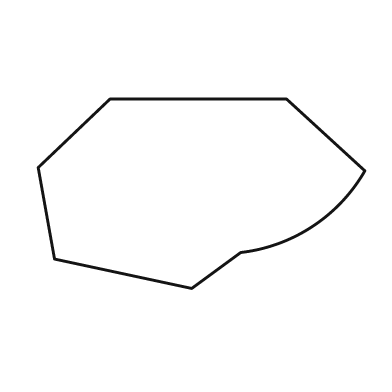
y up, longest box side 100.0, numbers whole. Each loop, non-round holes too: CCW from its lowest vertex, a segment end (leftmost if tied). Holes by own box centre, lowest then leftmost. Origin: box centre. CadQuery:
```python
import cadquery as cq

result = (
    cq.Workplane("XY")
    .moveTo(-3.0, -29.0)
    .lineTo(12.0, -18.0)
    .threePointArc((34.0, -10.0), (50.0, 7.0))
    .lineTo(26.0, 29.0)
    .lineTo(-28.0, 29.0)
    .lineTo(-50.0, 8.0)
    .lineTo(-45.0, -20.0)
    .close()
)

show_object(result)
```